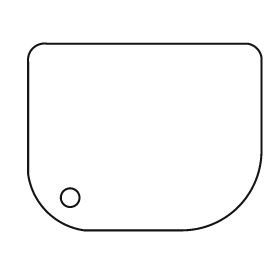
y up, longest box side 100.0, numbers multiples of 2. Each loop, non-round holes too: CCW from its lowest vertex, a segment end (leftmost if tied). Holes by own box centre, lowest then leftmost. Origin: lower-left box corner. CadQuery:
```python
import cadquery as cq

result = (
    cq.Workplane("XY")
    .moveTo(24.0, 0.0)
    .lineTo(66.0, 0.0)
    .threePointArc((90.0, 10.0), (100.0, 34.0))
    .lineTo(100.0, 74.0)
    .threePointArc((98.0, 78.0), (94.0, 80.0))
    .lineTo(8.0, 80.0)
    .threePointArc((2.0, 78.0), (0.0, 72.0))
    .lineTo(0.0, 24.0)
    .threePointArc((8.0, 8.0), (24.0, 0.0))
    .close()
    .moveTo(18.0, 14.0)
    .circle(4.0)
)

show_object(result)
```